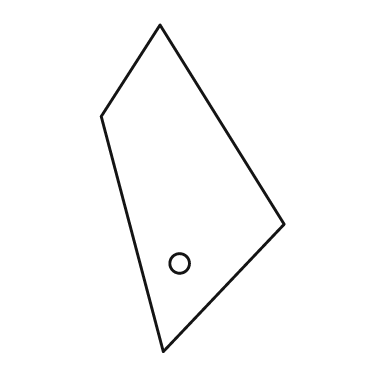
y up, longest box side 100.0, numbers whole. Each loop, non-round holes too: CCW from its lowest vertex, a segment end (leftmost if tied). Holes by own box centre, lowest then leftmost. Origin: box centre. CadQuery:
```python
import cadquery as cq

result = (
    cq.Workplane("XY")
    .moveTo(-9.0, -50.0)
    .lineTo(28.0, -11.0)
    .lineTo(-10.0, 50.0)
    .lineTo(-28.0, 22.0)
    .close()
    .moveTo(-4.0, -23.0)
    .circle(3.0)
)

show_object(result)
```